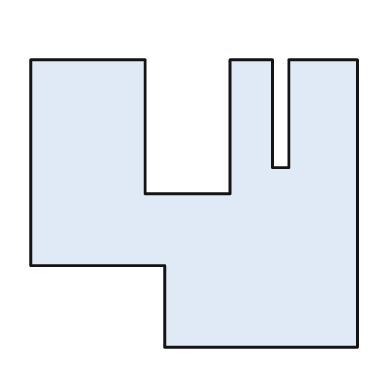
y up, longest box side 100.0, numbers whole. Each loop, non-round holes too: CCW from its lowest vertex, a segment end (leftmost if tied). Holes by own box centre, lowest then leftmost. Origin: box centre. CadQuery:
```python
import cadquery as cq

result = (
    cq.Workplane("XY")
    .moveTo(-9.0, -44.0)
    .lineTo(50.0, -44.0)
    .lineTo(50.0, 44.0)
    .lineTo(29.0, 44.0)
    .lineTo(29.0, 11.0)
    .lineTo(24.0, 11.0)
    .lineTo(24.0, 44.0)
    .lineTo(11.0, 44.0)
    .lineTo(11.0, 3.0)
    .lineTo(-15.0, 3.0)
    .lineTo(-15.0, 44.0)
    .lineTo(-50.0, 44.0)
    .lineTo(-50.0, -19.0)
    .lineTo(-9.0, -19.0)
    .close()
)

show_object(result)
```